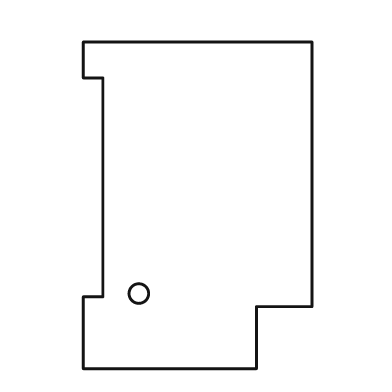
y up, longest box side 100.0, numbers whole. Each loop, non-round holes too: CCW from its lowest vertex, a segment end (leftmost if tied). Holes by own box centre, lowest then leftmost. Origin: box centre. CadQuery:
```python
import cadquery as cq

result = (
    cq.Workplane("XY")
    .moveTo(-35.0, -50.0)
    .lineTo(18.0, -50.0)
    .lineTo(18.0, -31.0)
    .lineTo(35.0, -31.0)
    .lineTo(35.0, 50.0)
    .lineTo(-35.0, 50.0)
    .lineTo(-35.0, 39.0)
    .lineTo(-29.0, 39.0)
    .lineTo(-29.0, -28.0)
    .lineTo(-35.0, -28.0)
    .close()
    .moveTo(-18.0, -27.0)
    .circle(3.0)
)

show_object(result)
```